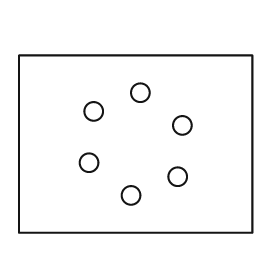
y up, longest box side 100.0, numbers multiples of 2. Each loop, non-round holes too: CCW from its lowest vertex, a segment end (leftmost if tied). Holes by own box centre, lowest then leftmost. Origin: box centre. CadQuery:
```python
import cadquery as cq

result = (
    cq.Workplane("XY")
    .moveTo(-50.0, -38.0)
    .lineTo(50.0, -38.0)
    .lineTo(50.0, 38.0)
    .lineTo(-50.0, 38.0)
    .close()
    .moveTo(-2.0, -22.0)
    .circle(4.0)
    .moveTo(18.0, -14.0)
    .circle(4.0)
    .moveTo(-20.0, -8.0)
    .circle(4.0)
    .moveTo(20.0, 8.0)
    .circle(4.0)
    .moveTo(-18.0, 14.0)
    .circle(4.0)
    .moveTo(2.0, 22.0)
    .circle(4.0)
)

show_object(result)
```